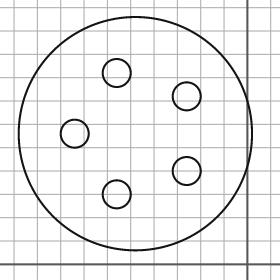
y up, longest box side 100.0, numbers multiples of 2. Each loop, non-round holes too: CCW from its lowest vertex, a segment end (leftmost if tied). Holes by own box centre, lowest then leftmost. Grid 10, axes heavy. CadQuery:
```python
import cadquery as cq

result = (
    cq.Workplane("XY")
    .moveTo(-48.0, 56.0)
    .circle(50.0)
    .moveTo(-56.0, 30.0)
    .circle(6.0)
    .moveTo(-26.0, 40.0)
    .circle(6.0)
    .moveTo(-74.0, 56.0)
    .circle(6.0)
    .moveTo(-26.0, 72.0)
    .circle(6.0)
    .moveTo(-56.0, 82.0)
    .circle(6.0)
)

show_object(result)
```